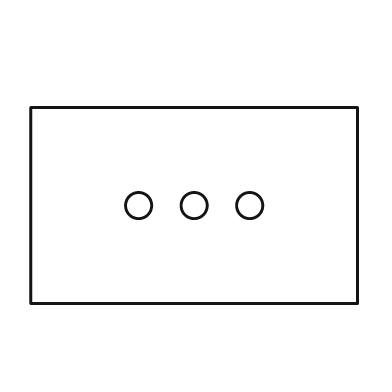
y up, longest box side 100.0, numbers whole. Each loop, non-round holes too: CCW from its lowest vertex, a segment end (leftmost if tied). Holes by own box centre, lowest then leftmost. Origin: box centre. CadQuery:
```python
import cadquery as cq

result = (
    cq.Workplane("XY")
    .moveTo(-50.0, -30.0)
    .lineTo(50.0, -30.0)
    .lineTo(50.0, 30.0)
    .lineTo(-50.0, 30.0)
    .close()
    .moveTo(-17.0, 0.0)
    .circle(4.0)
    .moveTo(0.0, 0.0)
    .circle(4.0)
    .moveTo(17.0, 0.0)
    .circle(4.0)
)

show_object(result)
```